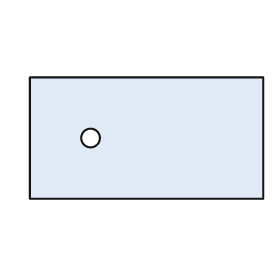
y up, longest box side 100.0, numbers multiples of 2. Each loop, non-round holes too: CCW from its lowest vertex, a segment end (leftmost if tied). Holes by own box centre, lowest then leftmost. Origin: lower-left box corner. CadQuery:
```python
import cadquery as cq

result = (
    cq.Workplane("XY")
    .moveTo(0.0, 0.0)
    .lineTo(100.0, 0.0)
    .lineTo(100.0, 52.0)
    .lineTo(0.0, 52.0)
    .close()
    .moveTo(26.0, 26.0)
    .circle(4.0)
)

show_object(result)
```